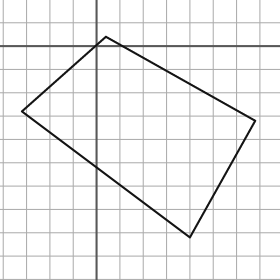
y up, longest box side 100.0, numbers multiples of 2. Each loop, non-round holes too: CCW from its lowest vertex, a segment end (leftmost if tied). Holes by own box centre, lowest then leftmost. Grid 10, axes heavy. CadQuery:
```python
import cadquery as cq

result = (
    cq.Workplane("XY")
    .moveTo(40.0, -82.0)
    .lineTo(68.0, -32.0)
    .lineTo(4.0, 4.0)
    .lineTo(-32.0, -28.0)
    .close()
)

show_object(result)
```